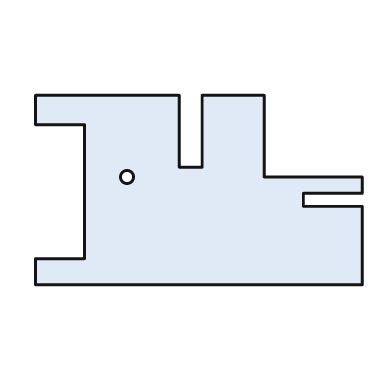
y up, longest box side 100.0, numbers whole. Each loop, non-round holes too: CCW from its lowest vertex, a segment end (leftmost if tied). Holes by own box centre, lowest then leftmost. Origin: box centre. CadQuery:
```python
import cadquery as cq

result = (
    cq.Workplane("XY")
    .moveTo(-50.0, -29.0)
    .lineTo(50.0, -29.0)
    .lineTo(50.0, -5.0)
    .lineTo(32.0, -5.0)
    .lineTo(32.0, -1.0)
    .lineTo(50.0, -1.0)
    .lineTo(50.0, 4.0)
    .lineTo(20.0, 4.0)
    .lineTo(20.0, 29.0)
    .lineTo(1.0, 29.0)
    .lineTo(1.0, 7.0)
    .lineTo(-6.0, 7.0)
    .lineTo(-6.0, 29.0)
    .lineTo(-50.0, 29.0)
    .lineTo(-50.0, 20.0)
    .lineTo(-35.0, 20.0)
    .lineTo(-35.0, -21.0)
    .lineTo(-50.0, -21.0)
    .close()
    .moveTo(-22.0, 4.0)
    .circle(2.0)
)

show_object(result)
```